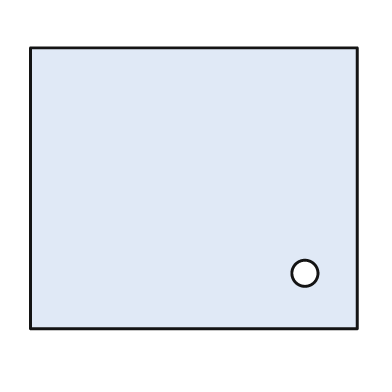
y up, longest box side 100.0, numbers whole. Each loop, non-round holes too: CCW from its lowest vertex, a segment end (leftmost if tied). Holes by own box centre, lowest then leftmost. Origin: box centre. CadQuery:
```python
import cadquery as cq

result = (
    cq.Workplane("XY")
    .moveTo(-50.0, -43.0)
    .lineTo(50.0, -43.0)
    .lineTo(50.0, 43.0)
    .lineTo(-50.0, 43.0)
    .close()
    .moveTo(34.0, -26.0)
    .circle(4.0)
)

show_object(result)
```